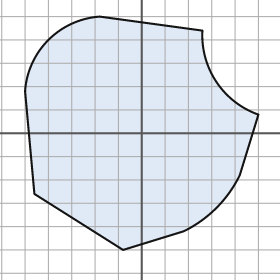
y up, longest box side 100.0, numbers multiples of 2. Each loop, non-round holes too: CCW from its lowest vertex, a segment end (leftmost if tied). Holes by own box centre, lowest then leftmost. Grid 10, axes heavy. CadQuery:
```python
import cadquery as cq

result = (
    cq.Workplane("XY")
    .moveTo(-8.0, -50.0)
    .lineTo(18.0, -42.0)
    .threePointArc((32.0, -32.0), (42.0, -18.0))
    .lineTo(50.0, 8.0)
    .threePointArc((32.0, 22.0), (26.0, 44.0))
    .lineTo(-18.0, 50.0)
    .threePointArc((-40.0, 40.0), (-50.0, 18.0))
    .lineTo(-46.0, -26.0)
    .close()
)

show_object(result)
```